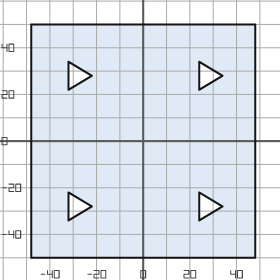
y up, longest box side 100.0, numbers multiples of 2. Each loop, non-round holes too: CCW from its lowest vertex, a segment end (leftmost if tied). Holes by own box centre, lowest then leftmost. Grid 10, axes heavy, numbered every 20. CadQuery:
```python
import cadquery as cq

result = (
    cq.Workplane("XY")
    .moveTo(-48.0, -50.0)
    .lineTo(48.0, -50.0)
    .lineTo(48.0, 50.0)
    .lineTo(-48.0, 50.0)
    .close()
    .moveTo(-32.0, -34.0)
    .lineTo(-22.0, -28.0)
    .lineTo(-32.0, -22.0)
    .close()
    .moveTo(24.0, -34.0)
    .lineTo(34.0, -28.0)
    .lineTo(24.0, -22.0)
    .close()
    .moveTo(-32.0, 22.0)
    .lineTo(-22.0, 28.0)
    .lineTo(-32.0, 34.0)
    .close()
    .moveTo(24.0, 22.0)
    .lineTo(34.0, 28.0)
    .lineTo(24.0, 34.0)
    .close()
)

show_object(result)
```